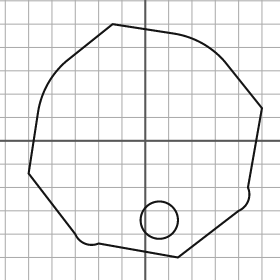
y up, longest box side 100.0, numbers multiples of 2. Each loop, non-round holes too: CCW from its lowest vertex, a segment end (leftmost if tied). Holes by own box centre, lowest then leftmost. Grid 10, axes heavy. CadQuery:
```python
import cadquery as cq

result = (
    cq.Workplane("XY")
    .moveTo(14.0, -50.0)
    .lineTo(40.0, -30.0)
    .threePointArc((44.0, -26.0), (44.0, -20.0))
    .lineTo(50.0, 14.0)
    .lineTo(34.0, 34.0)
    .threePointArc((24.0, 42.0), (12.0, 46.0))
    .lineTo(-14.0, 50.0)
    .lineTo(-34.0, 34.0)
    .threePointArc((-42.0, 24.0), (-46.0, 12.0))
    .lineTo(-50.0, -14.0)
    .lineTo(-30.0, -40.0)
    .threePointArc((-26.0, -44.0), (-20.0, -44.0))
    .close()
    .moveTo(6.0, -34.0)
    .circle(8.0)
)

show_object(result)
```